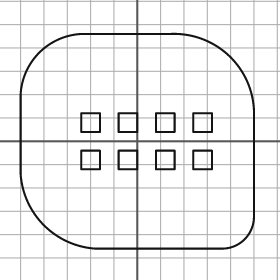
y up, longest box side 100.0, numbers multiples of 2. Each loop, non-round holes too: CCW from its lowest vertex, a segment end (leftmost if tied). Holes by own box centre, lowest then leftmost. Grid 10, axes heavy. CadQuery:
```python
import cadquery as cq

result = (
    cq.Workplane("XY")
    .moveTo(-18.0, -46.0)
    .lineTo(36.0, -46.0)
    .threePointArc((46.0, -42.0), (50.0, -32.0))
    .lineTo(50.0, 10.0)
    .threePointArc((40.0, 36.0), (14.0, 46.0))
    .lineTo(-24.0, 46.0)
    .threePointArc((-42.0, 38.0), (-50.0, 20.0))
    .lineTo(-50.0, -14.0)
    .threePointArc((-40.0, -36.0), (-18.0, -46.0))
    .close()
    .moveTo(-24.0, -12.0)
    .lineTo(-16.0, -12.0)
    .lineTo(-16.0, -4.0)
    .lineTo(-24.0, -4.0)
    .close()
    .moveTo(-8.0, -12.0)
    .lineTo(0.0, -12.0)
    .lineTo(0.0, -4.0)
    .lineTo(-8.0, -4.0)
    .close()
    .moveTo(8.0, -12.0)
    .lineTo(16.0, -12.0)
    .lineTo(16.0, -4.0)
    .lineTo(8.0, -4.0)
    .close()
    .moveTo(24.0, -12.0)
    .lineTo(32.0, -12.0)
    .lineTo(32.0, -4.0)
    .lineTo(24.0, -4.0)
    .close()
    .moveTo(-24.0, 4.0)
    .lineTo(-16.0, 4.0)
    .lineTo(-16.0, 12.0)
    .lineTo(-24.0, 12.0)
    .close()
    .moveTo(-8.0, 4.0)
    .lineTo(0.0, 4.0)
    .lineTo(0.0, 12.0)
    .lineTo(-8.0, 12.0)
    .close()
    .moveTo(8.0, 4.0)
    .lineTo(16.0, 4.0)
    .lineTo(16.0, 12.0)
    .lineTo(8.0, 12.0)
    .close()
    .moveTo(24.0, 4.0)
    .lineTo(32.0, 4.0)
    .lineTo(32.0, 12.0)
    .lineTo(24.0, 12.0)
    .close()
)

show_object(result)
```